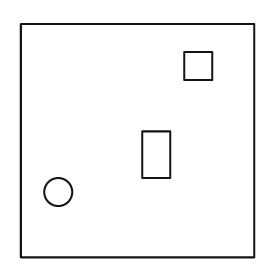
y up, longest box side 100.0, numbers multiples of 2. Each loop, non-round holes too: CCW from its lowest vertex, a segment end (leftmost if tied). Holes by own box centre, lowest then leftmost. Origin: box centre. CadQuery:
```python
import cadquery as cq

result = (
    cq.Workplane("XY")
    .moveTo(-50.0, -50.0)
    .lineTo(50.0, -50.0)
    .lineTo(50.0, 50.0)
    .lineTo(-50.0, 50.0)
    .close()
    .moveTo(-34.0, -22.0)
    .circle(6.0)
    .moveTo(2.0, -16.0)
    .lineTo(14.0, -16.0)
    .lineTo(14.0, 4.0)
    .lineTo(2.0, 4.0)
    .close()
    .moveTo(20.0, 26.0)
    .lineTo(32.0, 26.0)
    .lineTo(32.0, 38.0)
    .lineTo(20.0, 38.0)
    .close()
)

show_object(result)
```